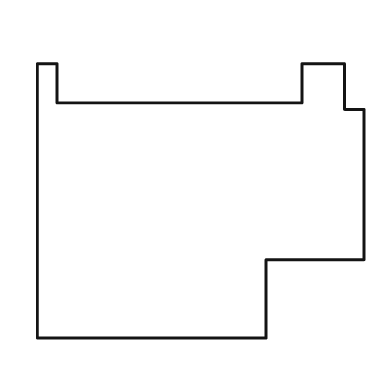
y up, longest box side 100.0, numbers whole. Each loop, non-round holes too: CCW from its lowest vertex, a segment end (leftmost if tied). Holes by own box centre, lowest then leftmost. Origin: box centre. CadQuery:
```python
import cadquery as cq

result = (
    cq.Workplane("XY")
    .moveTo(-50.0, -42.0)
    .lineTo(20.0, -42.0)
    .lineTo(20.0, -18.0)
    .lineTo(50.0, -18.0)
    .lineTo(50.0, 28.0)
    .lineTo(44.0, 28.0)
    .lineTo(44.0, 42.0)
    .lineTo(31.0, 42.0)
    .lineTo(31.0, 30.0)
    .lineTo(-44.0, 30.0)
    .lineTo(-44.0, 42.0)
    .lineTo(-50.0, 42.0)
    .close()
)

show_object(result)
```